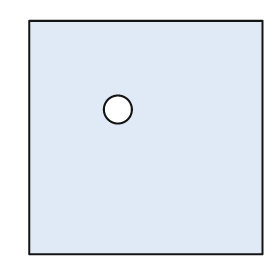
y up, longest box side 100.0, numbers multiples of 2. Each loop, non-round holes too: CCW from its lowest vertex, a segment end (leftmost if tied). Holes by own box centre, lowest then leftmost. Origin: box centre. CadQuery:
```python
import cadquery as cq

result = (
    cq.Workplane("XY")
    .moveTo(-50.0, -50.0)
    .lineTo(50.0, -50.0)
    .lineTo(50.0, 50.0)
    .lineTo(-50.0, 50.0)
    .close()
    .moveTo(-12.0, 12.0)
    .circle(6.0)
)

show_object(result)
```